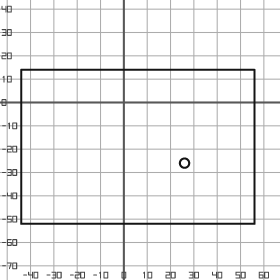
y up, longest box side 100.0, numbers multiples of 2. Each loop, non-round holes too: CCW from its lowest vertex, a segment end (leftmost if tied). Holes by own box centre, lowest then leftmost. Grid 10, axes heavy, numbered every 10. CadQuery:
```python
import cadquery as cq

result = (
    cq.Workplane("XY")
    .moveTo(-44.0, -52.0)
    .lineTo(56.0, -52.0)
    .lineTo(56.0, 14.0)
    .lineTo(-44.0, 14.0)
    .close()
    .moveTo(26.0, -26.0)
    .circle(2.0)
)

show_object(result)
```